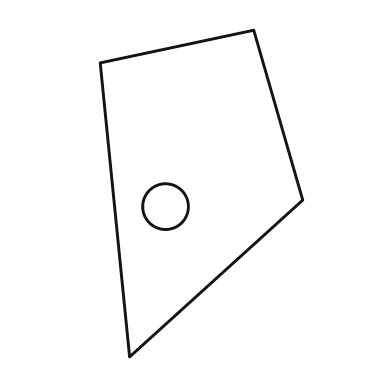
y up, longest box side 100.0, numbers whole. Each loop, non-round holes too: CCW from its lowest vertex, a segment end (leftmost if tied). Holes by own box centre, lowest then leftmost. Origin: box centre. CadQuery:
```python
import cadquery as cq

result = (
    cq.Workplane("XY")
    .moveTo(-22.0, -50.0)
    .lineTo(31.0, -2.0)
    .lineTo(16.0, 50.0)
    .lineTo(-31.0, 40.0)
    .close()
    .moveTo(-11.0, -4.0)
    .circle(7.0)
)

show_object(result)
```